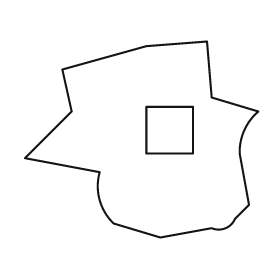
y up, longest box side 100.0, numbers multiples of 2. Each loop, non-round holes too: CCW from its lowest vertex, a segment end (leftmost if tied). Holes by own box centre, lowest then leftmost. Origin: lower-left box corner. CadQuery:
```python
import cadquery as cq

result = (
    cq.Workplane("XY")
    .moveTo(58.0, 0.0)
    .lineTo(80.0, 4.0)
    .threePointArc((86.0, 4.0), (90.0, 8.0))
    .lineTo(96.0, 14.0)
    .lineTo(92.0, 36.0)
    .threePointArc((94.0, 46.0), (100.0, 54.0))
    .lineTo(80.0, 60.0)
    .lineTo(78.0, 84.0)
    .lineTo(52.0, 82.0)
    .lineTo(16.0, 72.0)
    .lineTo(20.0, 54.0)
    .lineTo(0.0, 34.0)
    .lineTo(32.0, 28.0)
    .threePointArc((32.0, 16.0), (38.0, 6.0))
    .close()
    .moveTo(52.0, 36.0)
    .lineTo(72.0, 36.0)
    .lineTo(72.0, 56.0)
    .lineTo(52.0, 56.0)
    .close()
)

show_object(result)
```